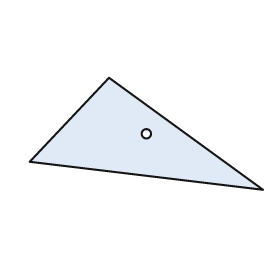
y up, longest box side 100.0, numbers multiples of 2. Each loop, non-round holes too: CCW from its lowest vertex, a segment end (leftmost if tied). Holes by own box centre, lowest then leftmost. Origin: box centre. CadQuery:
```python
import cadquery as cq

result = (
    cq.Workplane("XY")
    .moveTo(50.0, -24.0)
    .lineTo(-16.0, 24.0)
    .lineTo(-50.0, -12.0)
    .close()
    .moveTo(0.0, 0.0)
    .circle(2.0)
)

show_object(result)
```